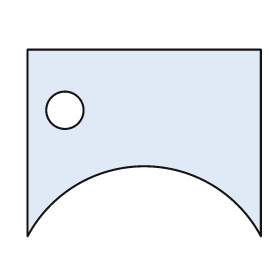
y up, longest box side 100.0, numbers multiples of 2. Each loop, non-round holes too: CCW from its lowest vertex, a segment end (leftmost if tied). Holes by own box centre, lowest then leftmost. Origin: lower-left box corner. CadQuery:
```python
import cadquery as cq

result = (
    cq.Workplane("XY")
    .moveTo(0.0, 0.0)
    .threePointArc((50.0, 30.0), (100.0, 0.0))
    .lineTo(100.0, 80.0)
    .lineTo(0.0, 80.0)
    .close()
    .moveTo(16.0, 54.0)
    .circle(8.0)
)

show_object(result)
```